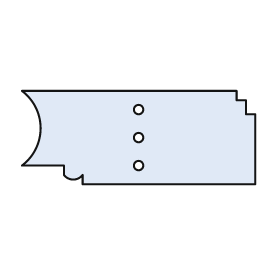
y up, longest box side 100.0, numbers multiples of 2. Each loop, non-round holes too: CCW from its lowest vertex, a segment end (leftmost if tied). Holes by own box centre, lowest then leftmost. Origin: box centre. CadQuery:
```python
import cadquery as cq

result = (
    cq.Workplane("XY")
    .moveTo(-24.0, -20.0)
    .lineTo(50.0, -20.0)
    .lineTo(50.0, 10.0)
    .lineTo(46.0, 10.0)
    .lineTo(46.0, 16.0)
    .lineTo(42.0, 16.0)
    .lineTo(42.0, 20.0)
    .lineTo(-50.0, 20.0)
    .threePointArc((-42.0, 4.0), (-50.0, -12.0))
    .lineTo(-32.0, -12.0)
    .lineTo(-32.0, -16.0)
    .threePointArc((-28.0, -18.0), (-24.0, -16.0))
    .close()
    .moveTo(0.0, -12.0)
    .circle(2.0)
    .moveTo(0.0, 0.0)
    .circle(2.0)
    .moveTo(0.0, 12.0)
    .circle(2.0)
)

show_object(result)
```